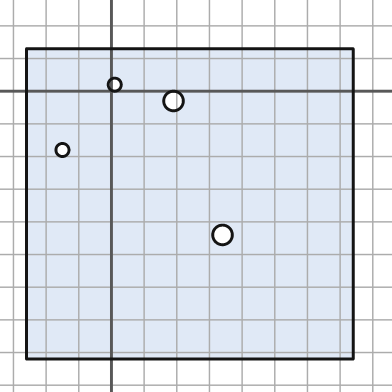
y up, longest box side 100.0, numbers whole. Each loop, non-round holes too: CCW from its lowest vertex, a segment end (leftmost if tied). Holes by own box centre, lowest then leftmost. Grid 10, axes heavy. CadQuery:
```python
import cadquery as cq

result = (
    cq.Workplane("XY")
    .moveTo(-26.0, -82.0)
    .lineTo(74.0, -82.0)
    .lineTo(74.0, 13.0)
    .lineTo(-26.0, 13.0)
    .close()
    .moveTo(34.0, -44.0)
    .circle(3.0)
    .moveTo(-15.0, -18.0)
    .circle(2.0)
    .moveTo(19.0, -3.0)
    .circle(3.0)
    .moveTo(1.0, 2.0)
    .circle(2.0)
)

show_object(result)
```